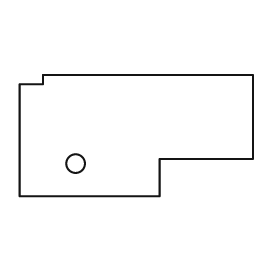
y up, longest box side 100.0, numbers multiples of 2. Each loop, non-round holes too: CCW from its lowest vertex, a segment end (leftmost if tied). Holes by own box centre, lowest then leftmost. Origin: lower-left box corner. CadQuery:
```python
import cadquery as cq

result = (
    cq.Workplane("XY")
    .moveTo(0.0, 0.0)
    .lineTo(60.0, 0.0)
    .lineTo(60.0, 16.0)
    .lineTo(100.0, 16.0)
    .lineTo(100.0, 52.0)
    .lineTo(10.0, 52.0)
    .lineTo(10.0, 48.0)
    .lineTo(0.0, 48.0)
    .close()
    .moveTo(24.0, 14.0)
    .circle(4.0)
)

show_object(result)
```